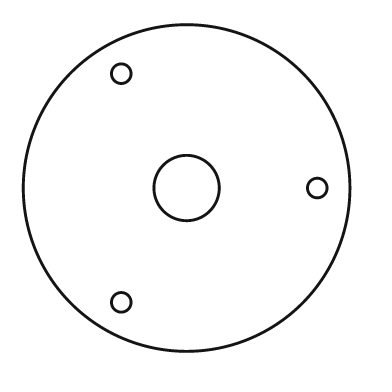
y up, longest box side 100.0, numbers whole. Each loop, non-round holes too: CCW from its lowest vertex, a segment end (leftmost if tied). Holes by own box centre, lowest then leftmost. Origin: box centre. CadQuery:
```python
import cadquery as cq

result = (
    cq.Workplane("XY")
    .moveTo(0.0, 0.0)
    .circle(50.0)
    .moveTo(-20.0, -35.0)
    .circle(3.0)
    .moveTo(0.0, 0.0)
    .circle(10.0)
    .moveTo(40.0, 0.0)
    .circle(3.0)
    .moveTo(-20.0, 35.0)
    .circle(3.0)
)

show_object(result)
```